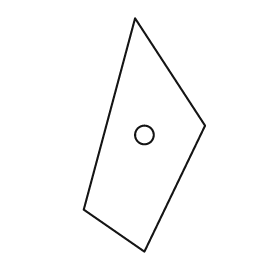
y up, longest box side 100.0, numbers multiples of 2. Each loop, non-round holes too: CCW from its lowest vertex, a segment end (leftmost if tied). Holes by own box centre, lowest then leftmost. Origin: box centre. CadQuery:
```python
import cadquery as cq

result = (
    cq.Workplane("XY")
    .moveTo(0.0, -50.0)
    .lineTo(26.0, 4.0)
    .lineTo(-4.0, 50.0)
    .lineTo(-26.0, -32.0)
    .close()
    .moveTo(0.0, 0.0)
    .circle(4.0)
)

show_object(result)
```